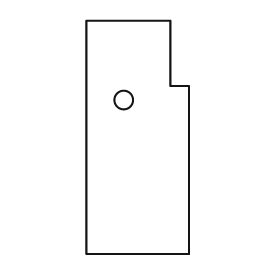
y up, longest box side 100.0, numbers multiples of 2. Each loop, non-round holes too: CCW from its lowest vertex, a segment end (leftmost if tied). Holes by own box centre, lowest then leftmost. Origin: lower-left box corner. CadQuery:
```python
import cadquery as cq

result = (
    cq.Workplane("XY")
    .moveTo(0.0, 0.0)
    .lineTo(44.0, 0.0)
    .lineTo(44.0, 72.0)
    .lineTo(36.0, 72.0)
    .lineTo(36.0, 100.0)
    .lineTo(0.0, 100.0)
    .close()
    .moveTo(16.0, 66.0)
    .circle(4.0)
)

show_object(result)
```